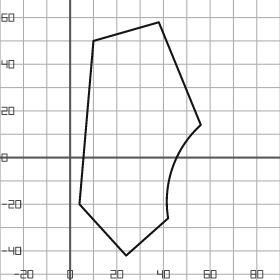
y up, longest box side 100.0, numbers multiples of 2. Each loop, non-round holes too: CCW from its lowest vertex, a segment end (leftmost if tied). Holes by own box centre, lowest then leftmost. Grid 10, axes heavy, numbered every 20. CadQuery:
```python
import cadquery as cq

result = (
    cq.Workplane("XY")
    .moveTo(24.0, -42.0)
    .lineTo(42.0, -26.0)
    .threePointArc((44.0, -4.0), (56.0, 14.0))
    .lineTo(38.0, 58.0)
    .lineTo(10.0, 50.0)
    .lineTo(4.0, -20.0)
    .close()
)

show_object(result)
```